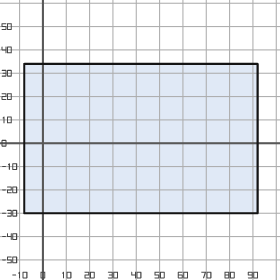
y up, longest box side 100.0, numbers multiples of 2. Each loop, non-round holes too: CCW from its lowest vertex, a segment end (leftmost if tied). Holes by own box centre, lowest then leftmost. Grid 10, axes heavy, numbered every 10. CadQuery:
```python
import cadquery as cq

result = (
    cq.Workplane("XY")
    .moveTo(-8.0, -30.0)
    .lineTo(92.0, -30.0)
    .lineTo(92.0, 34.0)
    .lineTo(-8.0, 34.0)
    .close()
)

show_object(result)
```